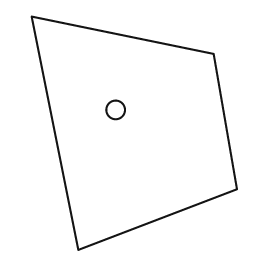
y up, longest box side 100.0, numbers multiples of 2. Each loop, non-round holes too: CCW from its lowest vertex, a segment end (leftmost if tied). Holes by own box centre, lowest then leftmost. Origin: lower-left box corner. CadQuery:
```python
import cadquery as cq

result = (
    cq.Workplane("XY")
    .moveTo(20.0, 0.0)
    .lineTo(88.0, 26.0)
    .lineTo(78.0, 84.0)
    .lineTo(0.0, 100.0)
    .close()
    .moveTo(36.0, 60.0)
    .circle(4.0)
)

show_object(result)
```